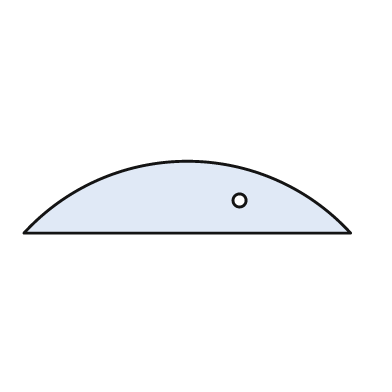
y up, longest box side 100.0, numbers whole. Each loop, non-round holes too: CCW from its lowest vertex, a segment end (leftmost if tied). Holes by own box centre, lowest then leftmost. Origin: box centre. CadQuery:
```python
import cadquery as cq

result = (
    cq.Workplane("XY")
    .moveTo(-50.0, -11.0)
    .lineTo(50.0, -11.0)
    .threePointArc((0.0, 11.0), (-50.0, -11.0))
    .close()
    .moveTo(16.0, -1.0)
    .circle(2.0)
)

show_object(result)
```